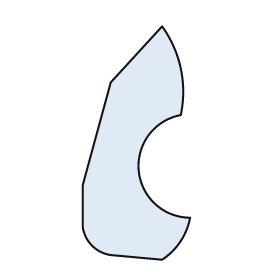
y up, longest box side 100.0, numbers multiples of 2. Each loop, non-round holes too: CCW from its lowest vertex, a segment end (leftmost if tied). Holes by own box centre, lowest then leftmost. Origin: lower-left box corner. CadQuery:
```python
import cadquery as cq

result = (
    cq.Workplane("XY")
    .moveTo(34.0, 0.0)
    .threePointArc((42.0, 8.0), (46.0, 18.0))
    .threePointArc((24.0, 38.0), (42.0, 62.0))
    .threePointArc((42.0, 82.0), (34.0, 100.0))
    .lineTo(12.0, 76.0)
    .lineTo(0.0, 32.0)
    .lineTo(0.0, 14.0)
    .threePointArc((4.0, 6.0), (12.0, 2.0))
    .close()
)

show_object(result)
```